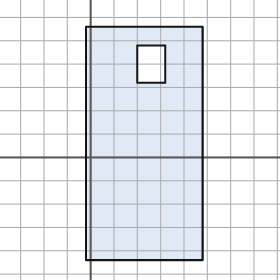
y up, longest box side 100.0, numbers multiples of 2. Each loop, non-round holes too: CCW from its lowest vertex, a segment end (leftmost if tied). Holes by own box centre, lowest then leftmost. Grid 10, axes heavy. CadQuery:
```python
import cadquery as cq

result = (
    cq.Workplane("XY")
    .moveTo(-2.0, -44.0)
    .lineTo(48.0, -44.0)
    .lineTo(48.0, 56.0)
    .lineTo(-2.0, 56.0)
    .close()
    .moveTo(20.0, 32.0)
    .lineTo(32.0, 32.0)
    .lineTo(32.0, 48.0)
    .lineTo(20.0, 48.0)
    .close()
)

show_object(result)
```